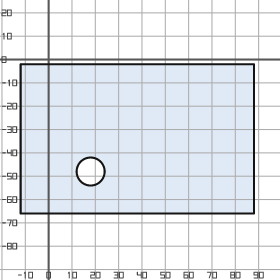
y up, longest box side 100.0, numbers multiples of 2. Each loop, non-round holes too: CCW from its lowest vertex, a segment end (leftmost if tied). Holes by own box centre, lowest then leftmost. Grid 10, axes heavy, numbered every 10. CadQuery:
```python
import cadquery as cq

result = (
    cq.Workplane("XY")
    .moveTo(-12.0, -66.0)
    .lineTo(88.0, -66.0)
    .lineTo(88.0, -2.0)
    .lineTo(-12.0, -2.0)
    .close()
    .moveTo(18.0, -48.0)
    .circle(6.0)
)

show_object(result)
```